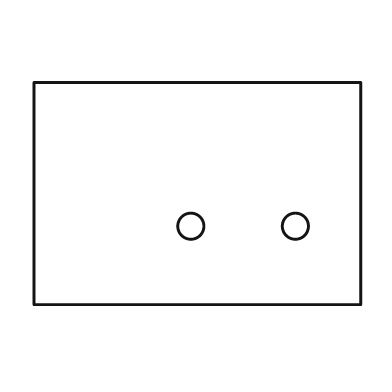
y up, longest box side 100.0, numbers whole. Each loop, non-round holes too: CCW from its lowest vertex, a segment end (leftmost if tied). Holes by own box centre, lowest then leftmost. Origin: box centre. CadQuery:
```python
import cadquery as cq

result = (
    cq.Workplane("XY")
    .moveTo(-50.0, -34.0)
    .lineTo(50.0, -34.0)
    .lineTo(50.0, 34.0)
    .lineTo(-50.0, 34.0)
    .close()
    .moveTo(-2.0, -10.0)
    .circle(4.0)
    .moveTo(30.0, -10.0)
    .circle(4.0)
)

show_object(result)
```